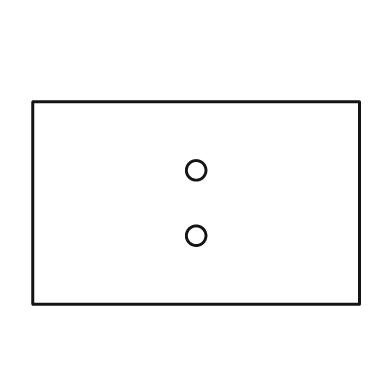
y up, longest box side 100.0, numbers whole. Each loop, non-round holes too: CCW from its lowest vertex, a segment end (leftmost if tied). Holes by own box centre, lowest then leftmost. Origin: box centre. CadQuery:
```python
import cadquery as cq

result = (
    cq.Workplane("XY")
    .moveTo(-50.0, -31.0)
    .lineTo(50.0, -31.0)
    .lineTo(50.0, 31.0)
    .lineTo(-50.0, 31.0)
    .close()
    .moveTo(0.0, -10.0)
    .circle(3.0)
    .moveTo(0.0, 10.0)
    .circle(3.0)
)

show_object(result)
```